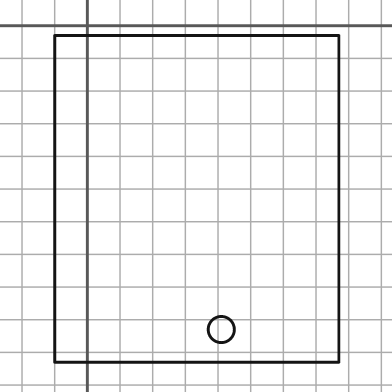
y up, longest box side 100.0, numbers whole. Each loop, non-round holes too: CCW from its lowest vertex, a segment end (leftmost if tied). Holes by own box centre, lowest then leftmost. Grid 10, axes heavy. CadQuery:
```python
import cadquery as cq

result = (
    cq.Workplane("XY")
    .moveTo(-10.0, -103.0)
    .lineTo(77.0, -103.0)
    .lineTo(77.0, -3.0)
    .lineTo(-10.0, -3.0)
    .close()
    .moveTo(41.0, -93.0)
    .circle(4.0)
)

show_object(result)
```